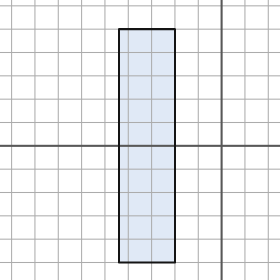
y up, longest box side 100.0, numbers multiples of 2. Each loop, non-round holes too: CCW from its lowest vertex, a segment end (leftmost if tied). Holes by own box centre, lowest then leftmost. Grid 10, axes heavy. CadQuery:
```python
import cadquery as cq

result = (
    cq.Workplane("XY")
    .moveTo(-44.0, -50.0)
    .lineTo(-20.0, -50.0)
    .lineTo(-20.0, 50.0)
    .lineTo(-44.0, 50.0)
    .close()
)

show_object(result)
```